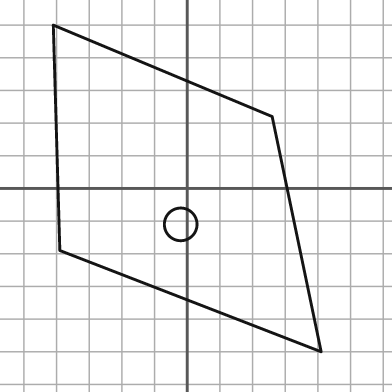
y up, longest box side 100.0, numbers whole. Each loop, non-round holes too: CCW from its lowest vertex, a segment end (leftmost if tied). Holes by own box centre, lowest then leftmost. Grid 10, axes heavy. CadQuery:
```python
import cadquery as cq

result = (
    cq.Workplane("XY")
    .moveTo(41.0, -50.0)
    .lineTo(26.0, 22.0)
    .lineTo(-41.0, 50.0)
    .lineTo(-39.0, -19.0)
    .close()
    .moveTo(-2.0, -11.0)
    .circle(5.0)
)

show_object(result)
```